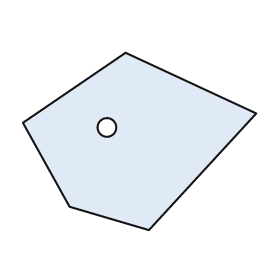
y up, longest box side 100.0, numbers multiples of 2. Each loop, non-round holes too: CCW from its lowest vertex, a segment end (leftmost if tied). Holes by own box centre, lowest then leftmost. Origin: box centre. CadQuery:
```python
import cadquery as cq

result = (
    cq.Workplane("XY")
    .moveTo(4.0, -38.0)
    .lineTo(50.0, 12.0)
    .lineTo(-6.0, 38.0)
    .lineTo(-50.0, 8.0)
    .lineTo(-30.0, -28.0)
    .close()
    .moveTo(-14.0, 6.0)
    .circle(4.0)
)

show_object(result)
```